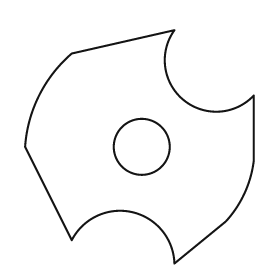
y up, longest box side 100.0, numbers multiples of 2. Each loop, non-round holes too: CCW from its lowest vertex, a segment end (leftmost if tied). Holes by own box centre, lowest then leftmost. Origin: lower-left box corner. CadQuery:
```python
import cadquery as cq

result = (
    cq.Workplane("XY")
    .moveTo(64.0, 0.0)
    .lineTo(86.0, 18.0)
    .threePointArc((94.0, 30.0), (98.0, 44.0))
    .lineTo(98.0, 72.0)
    .threePointArc((68.0, 70.0), (64.0, 100.0))
    .lineTo(20.0, 90.0)
    .threePointArc((6.0, 72.0), (0.0, 50.0))
    .lineTo(20.0, 10.0)
    .threePointArc((46.0, 22.0), (64.0, 0.0))
    .close()
    .moveTo(50.0, 50.0)
    .circle(12.0)
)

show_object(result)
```